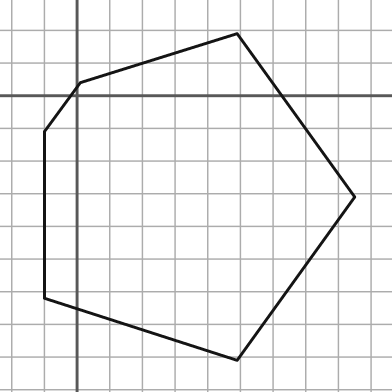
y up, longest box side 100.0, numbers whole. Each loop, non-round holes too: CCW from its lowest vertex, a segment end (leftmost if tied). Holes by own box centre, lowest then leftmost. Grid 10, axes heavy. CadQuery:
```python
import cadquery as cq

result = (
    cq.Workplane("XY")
    .moveTo(49.0, -81.0)
    .lineTo(85.0, -31.0)
    .lineTo(49.0, 19.0)
    .lineTo(1.0, 4.0)
    .lineTo(-10.0, -11.0)
    .lineTo(-10.0, -62.0)
    .close()
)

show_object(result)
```